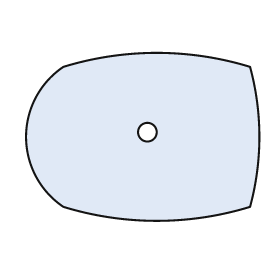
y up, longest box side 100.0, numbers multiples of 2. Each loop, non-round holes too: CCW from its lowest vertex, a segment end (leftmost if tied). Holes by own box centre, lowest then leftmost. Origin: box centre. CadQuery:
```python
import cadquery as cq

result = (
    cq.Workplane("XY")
    .moveTo(-34.0, -30.0)
    .threePointArc((6.0, -36.0), (46.0, -30.0))
    .threePointArc((50.0, 0.0), (46.0, 30.0))
    .threePointArc((6.0, 36.0), (-34.0, 30.0))
    .threePointArc((-50.0, 0.0), (-34.0, -30.0))
    .close()
    .moveTo(2.0, 2.0)
    .circle(4.0)
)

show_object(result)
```